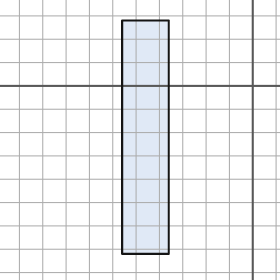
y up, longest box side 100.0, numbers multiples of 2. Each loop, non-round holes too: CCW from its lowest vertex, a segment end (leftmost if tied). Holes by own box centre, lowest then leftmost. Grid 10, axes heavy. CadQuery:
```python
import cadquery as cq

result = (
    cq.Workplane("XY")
    .moveTo(-56.0, -72.0)
    .lineTo(-36.0, -72.0)
    .lineTo(-36.0, 28.0)
    .lineTo(-56.0, 28.0)
    .close()
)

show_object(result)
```